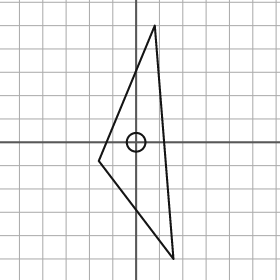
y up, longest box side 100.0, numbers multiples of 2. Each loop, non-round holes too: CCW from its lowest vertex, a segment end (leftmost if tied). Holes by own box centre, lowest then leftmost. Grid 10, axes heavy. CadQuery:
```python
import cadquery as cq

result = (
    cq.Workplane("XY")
    .moveTo(16.0, -50.0)
    .lineTo(8.0, 50.0)
    .lineTo(-16.0, -8.0)
    .close()
    .moveTo(0.0, 0.0)
    .circle(4.0)
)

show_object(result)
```